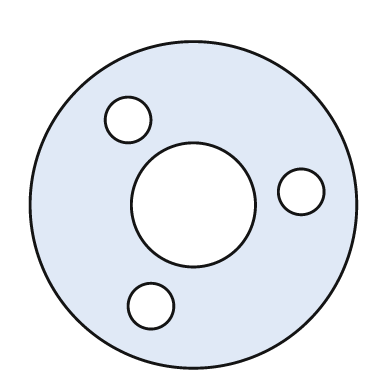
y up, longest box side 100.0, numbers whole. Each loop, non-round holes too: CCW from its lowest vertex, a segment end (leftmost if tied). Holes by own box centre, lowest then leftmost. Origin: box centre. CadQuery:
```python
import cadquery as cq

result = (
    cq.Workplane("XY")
    .moveTo(0.0, 0.0)
    .circle(50.0)
    .moveTo(-13.0, -31.0)
    .circle(7.0)
    .moveTo(0.0, 0.0)
    .circle(19.0)
    .moveTo(33.0, 4.0)
    .circle(7.0)
    .moveTo(-20.0, 26.0)
    .circle(7.0)
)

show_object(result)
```